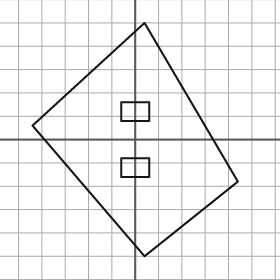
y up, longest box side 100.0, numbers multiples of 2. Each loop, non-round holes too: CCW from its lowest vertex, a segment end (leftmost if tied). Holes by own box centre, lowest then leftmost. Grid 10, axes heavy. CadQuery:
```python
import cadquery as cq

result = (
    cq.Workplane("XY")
    .moveTo(4.0, -50.0)
    .lineTo(44.0, -18.0)
    .lineTo(4.0, 50.0)
    .lineTo(-44.0, 6.0)
    .close()
    .moveTo(-6.0, -16.0)
    .lineTo(6.0, -16.0)
    .lineTo(6.0, -8.0)
    .lineTo(-6.0, -8.0)
    .close()
    .moveTo(-6.0, 8.0)
    .lineTo(6.0, 8.0)
    .lineTo(6.0, 16.0)
    .lineTo(-6.0, 16.0)
    .close()
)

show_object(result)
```